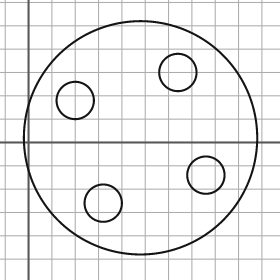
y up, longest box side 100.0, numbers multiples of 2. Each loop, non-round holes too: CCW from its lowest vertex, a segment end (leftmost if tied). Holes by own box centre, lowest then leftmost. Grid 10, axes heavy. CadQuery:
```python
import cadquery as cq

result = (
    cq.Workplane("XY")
    .moveTo(48.0, 2.0)
    .circle(50.0)
    .moveTo(32.0, -26.0)
    .circle(8.0)
    .moveTo(76.0, -14.0)
    .circle(8.0)
    .moveTo(20.0, 18.0)
    .circle(8.0)
    .moveTo(64.0, 30.0)
    .circle(8.0)
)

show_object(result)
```